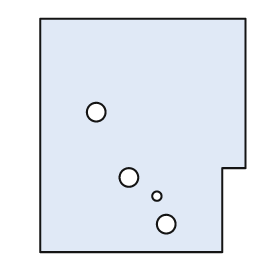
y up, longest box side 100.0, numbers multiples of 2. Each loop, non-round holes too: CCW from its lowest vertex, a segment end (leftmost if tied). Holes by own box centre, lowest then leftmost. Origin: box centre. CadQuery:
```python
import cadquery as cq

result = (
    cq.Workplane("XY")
    .moveTo(-44.0, -50.0)
    .lineTo(34.0, -50.0)
    .lineTo(34.0, -14.0)
    .lineTo(44.0, -14.0)
    .lineTo(44.0, 50.0)
    .lineTo(-44.0, 50.0)
    .close()
    .moveTo(10.0, -38.0)
    .circle(4.0)
    .moveTo(6.0, -26.0)
    .circle(2.0)
    .moveTo(-6.0, -18.0)
    .circle(4.0)
    .moveTo(-20.0, 10.0)
    .circle(4.0)
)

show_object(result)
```